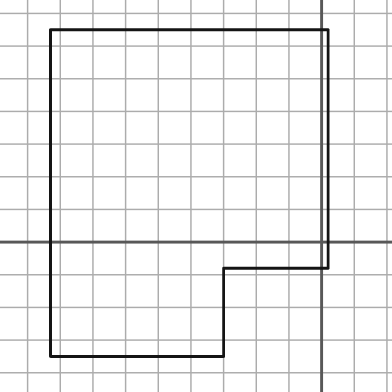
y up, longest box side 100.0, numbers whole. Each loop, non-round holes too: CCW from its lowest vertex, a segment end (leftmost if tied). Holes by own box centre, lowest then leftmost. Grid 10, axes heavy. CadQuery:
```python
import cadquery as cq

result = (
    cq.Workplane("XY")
    .moveTo(-83.0, -35.0)
    .lineTo(-30.0, -35.0)
    .lineTo(-30.0, -8.0)
    .lineTo(2.0, -8.0)
    .lineTo(2.0, 65.0)
    .lineTo(-83.0, 65.0)
    .close()
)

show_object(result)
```